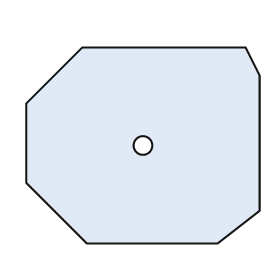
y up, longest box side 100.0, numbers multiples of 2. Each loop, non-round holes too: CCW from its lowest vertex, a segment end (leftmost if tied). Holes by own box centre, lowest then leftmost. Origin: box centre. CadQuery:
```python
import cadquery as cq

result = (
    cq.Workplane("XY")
    .moveTo(-24.0, -42.0)
    .lineTo(32.0, -42.0)
    .lineTo(50.0, -28.0)
    .lineTo(50.0, 30.0)
    .lineTo(44.0, 42.0)
    .lineTo(-26.0, 42.0)
    .lineTo(-50.0, 18.0)
    .lineTo(-50.0, -16.0)
    .close()
    .moveTo(0.0, 0.0)
    .circle(4.0)
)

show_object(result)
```